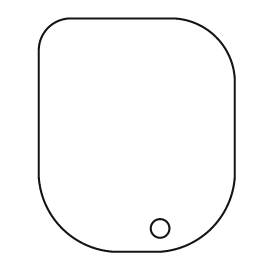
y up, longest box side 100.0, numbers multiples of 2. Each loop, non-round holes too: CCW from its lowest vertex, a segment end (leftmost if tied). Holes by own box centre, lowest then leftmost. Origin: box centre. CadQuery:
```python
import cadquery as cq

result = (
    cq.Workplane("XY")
    .moveTo(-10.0, -50.0)
    .lineTo(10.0, -50.0)
    .threePointArc((32.0, -40.0), (42.0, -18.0))
    .lineTo(42.0, 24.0)
    .threePointArc((34.0, 42.0), (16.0, 50.0))
    .lineTo(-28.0, 50.0)
    .threePointArc((-38.0, 46.0), (-42.0, 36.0))
    .lineTo(-42.0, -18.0)
    .threePointArc((-32.0, -40.0), (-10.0, -50.0))
    .close()
    .moveTo(10.0, -40.0)
    .circle(4.0)
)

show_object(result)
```